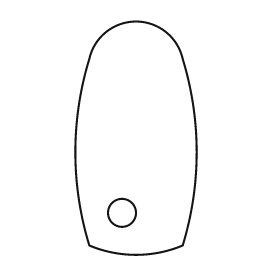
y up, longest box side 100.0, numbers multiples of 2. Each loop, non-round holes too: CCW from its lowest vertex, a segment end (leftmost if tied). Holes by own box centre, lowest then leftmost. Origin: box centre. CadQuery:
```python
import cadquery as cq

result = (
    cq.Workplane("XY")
    .moveTo(-20.0, -46.0)
    .threePointArc((0.0, -50.0), (20.0, -46.0))
    .threePointArc((26.0, -6.0), (20.0, 34.0))
    .threePointArc((0.0, 50.0), (-20.0, 34.0))
    .threePointArc((-26.0, -6.0), (-20.0, -46.0))
    .close()
    .moveTo(-6.0, -32.0)
    .circle(6.0)
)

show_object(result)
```